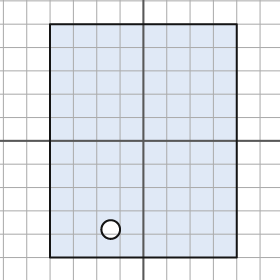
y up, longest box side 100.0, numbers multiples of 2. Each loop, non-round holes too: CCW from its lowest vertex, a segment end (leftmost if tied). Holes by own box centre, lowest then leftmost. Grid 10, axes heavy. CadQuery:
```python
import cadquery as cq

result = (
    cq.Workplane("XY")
    .moveTo(-40.0, -50.0)
    .lineTo(40.0, -50.0)
    .lineTo(40.0, 50.0)
    .lineTo(-40.0, 50.0)
    .close()
    .moveTo(-14.0, -38.0)
    .circle(4.0)
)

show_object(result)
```